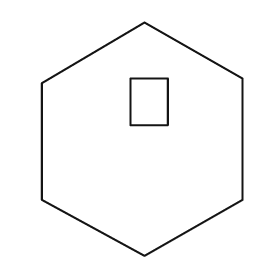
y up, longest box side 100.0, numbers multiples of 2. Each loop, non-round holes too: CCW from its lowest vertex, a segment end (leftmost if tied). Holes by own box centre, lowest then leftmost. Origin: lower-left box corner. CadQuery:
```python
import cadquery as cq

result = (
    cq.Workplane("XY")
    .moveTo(44.0, 0.0)
    .lineTo(86.0, 24.0)
    .lineTo(86.0, 76.0)
    .lineTo(44.0, 100.0)
    .lineTo(0.0, 74.0)
    .lineTo(0.0, 24.0)
    .close()
    .moveTo(38.0, 56.0)
    .lineTo(54.0, 56.0)
    .lineTo(54.0, 76.0)
    .lineTo(38.0, 76.0)
    .close()
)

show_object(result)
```